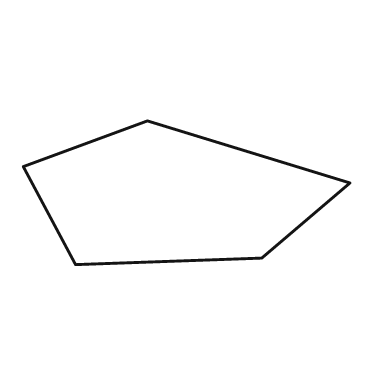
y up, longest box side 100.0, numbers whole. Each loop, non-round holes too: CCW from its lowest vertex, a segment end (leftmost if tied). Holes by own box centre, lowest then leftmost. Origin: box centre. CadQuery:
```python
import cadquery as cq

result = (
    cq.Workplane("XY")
    .moveTo(-34.0, -22.0)
    .lineTo(23.0, -20.0)
    .lineTo(50.0, 3.0)
    .lineTo(-12.0, 22.0)
    .lineTo(-50.0, 8.0)
    .close()
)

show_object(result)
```